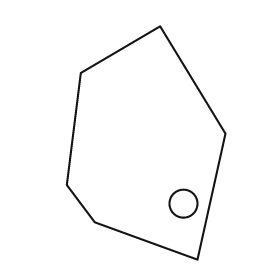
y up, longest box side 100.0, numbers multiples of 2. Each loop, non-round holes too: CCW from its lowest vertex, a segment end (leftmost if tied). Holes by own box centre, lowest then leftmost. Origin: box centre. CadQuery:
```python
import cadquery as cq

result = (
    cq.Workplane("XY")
    .moveTo(22.0, -50.0)
    .lineTo(34.0, 4.0)
    .lineTo(6.0, 50.0)
    .lineTo(-28.0, 30.0)
    .lineTo(-34.0, -18.0)
    .lineTo(-22.0, -34.0)
    .close()
    .moveTo(16.0, -26.0)
    .circle(6.0)
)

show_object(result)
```